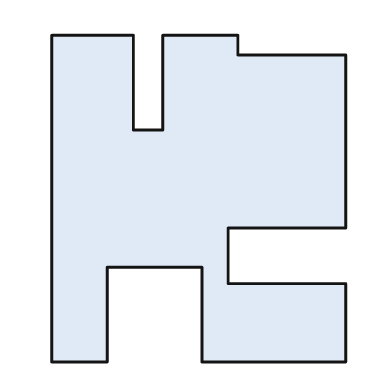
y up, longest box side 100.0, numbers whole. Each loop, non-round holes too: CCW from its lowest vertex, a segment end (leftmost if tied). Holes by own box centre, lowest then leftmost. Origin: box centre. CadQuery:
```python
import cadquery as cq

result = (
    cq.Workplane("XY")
    .moveTo(-45.0, -50.0)
    .lineTo(-28.0, -50.0)
    .lineTo(-28.0, -21.0)
    .lineTo(1.0, -21.0)
    .lineTo(1.0, -50.0)
    .lineTo(45.0, -50.0)
    .lineTo(45.0, -26.0)
    .lineTo(9.0, -26.0)
    .lineTo(9.0, -9.0)
    .lineTo(45.0, -9.0)
    .lineTo(45.0, 44.0)
    .lineTo(12.0, 44.0)
    .lineTo(12.0, 50.0)
    .lineTo(-11.0, 50.0)
    .lineTo(-11.0, 21.0)
    .lineTo(-20.0, 21.0)
    .lineTo(-20.0, 50.0)
    .lineTo(-45.0, 50.0)
    .close()
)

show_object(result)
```